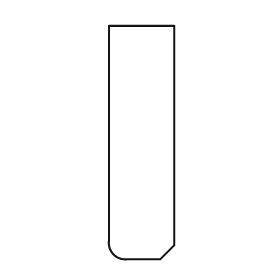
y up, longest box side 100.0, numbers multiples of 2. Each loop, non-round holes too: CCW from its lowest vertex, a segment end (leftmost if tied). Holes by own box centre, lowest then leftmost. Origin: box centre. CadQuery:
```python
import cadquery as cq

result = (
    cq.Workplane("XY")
    .moveTo(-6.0, -50.0)
    .lineTo(8.0, -50.0)
    .lineTo(14.0, -44.0)
    .lineTo(14.0, 50.0)
    .lineTo(-14.0, 50.0)
    .lineTo(-14.0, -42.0)
    .threePointArc((-12.0, -48.0), (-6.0, -50.0))
    .close()
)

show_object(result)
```